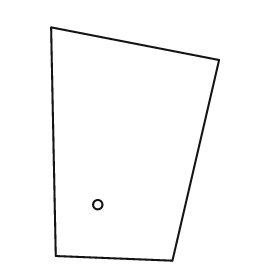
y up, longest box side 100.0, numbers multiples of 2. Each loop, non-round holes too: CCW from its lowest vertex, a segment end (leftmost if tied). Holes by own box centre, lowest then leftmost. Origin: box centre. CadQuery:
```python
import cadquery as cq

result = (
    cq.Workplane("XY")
    .moveTo(16.0, -50.0)
    .lineTo(36.0, 36.0)
    .lineTo(-36.0, 50.0)
    .lineTo(-34.0, -48.0)
    .close()
    .moveTo(-16.0, -26.0)
    .circle(2.0)
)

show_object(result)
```